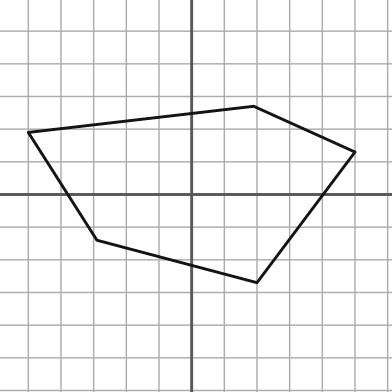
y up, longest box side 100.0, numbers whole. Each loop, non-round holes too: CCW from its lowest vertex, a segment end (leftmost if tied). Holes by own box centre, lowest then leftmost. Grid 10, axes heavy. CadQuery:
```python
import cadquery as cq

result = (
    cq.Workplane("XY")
    .moveTo(20.0, -27.0)
    .lineTo(50.0, 13.0)
    .lineTo(19.0, 27.0)
    .lineTo(-50.0, 19.0)
    .lineTo(-29.0, -14.0)
    .close()
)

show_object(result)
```